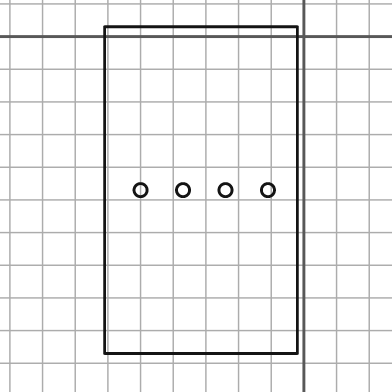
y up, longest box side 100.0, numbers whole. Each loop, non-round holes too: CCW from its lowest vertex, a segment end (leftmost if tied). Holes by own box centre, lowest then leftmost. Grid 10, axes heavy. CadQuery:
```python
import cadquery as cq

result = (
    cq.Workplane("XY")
    .moveTo(-61.0, -97.0)
    .lineTo(-2.0, -97.0)
    .lineTo(-2.0, 3.0)
    .lineTo(-61.0, 3.0)
    .close()
    .moveTo(-50.0, -47.0)
    .circle(2.0)
    .moveTo(-37.0, -47.0)
    .circle(2.0)
    .moveTo(-24.0, -47.0)
    .circle(2.0)
    .moveTo(-11.0, -47.0)
    .circle(2.0)
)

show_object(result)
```